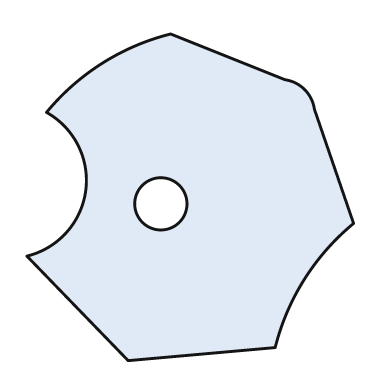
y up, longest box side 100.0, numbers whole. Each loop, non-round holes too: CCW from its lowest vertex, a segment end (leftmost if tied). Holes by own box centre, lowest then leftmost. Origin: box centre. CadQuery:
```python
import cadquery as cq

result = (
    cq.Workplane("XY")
    .moveTo(-19.0, -50.0)
    .lineTo(26.0, -46.0)
    .threePointArc((35.0, -25.0), (50.0, -8.0))
    .lineTo(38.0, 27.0)
    .threePointArc((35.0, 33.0), (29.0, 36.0))
    .lineTo(-6.0, 50.0)
    .threePointArc((-27.0, 41.0), (-44.0, 26.0))
    .threePointArc((-32.0, 2.0), (-50.0, -18.0))
    .close()
    .moveTo(-9.0, -2.0)
    .circle(8.0)
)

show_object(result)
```